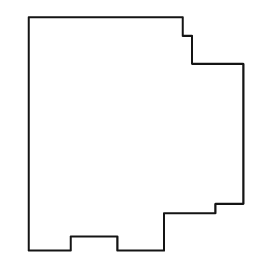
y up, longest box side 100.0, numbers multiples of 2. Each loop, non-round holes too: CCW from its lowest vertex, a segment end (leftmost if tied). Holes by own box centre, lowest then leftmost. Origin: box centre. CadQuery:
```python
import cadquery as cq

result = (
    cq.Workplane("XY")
    .moveTo(-46.0, -50.0)
    .lineTo(-28.0, -50.0)
    .lineTo(-28.0, -44.0)
    .lineTo(-8.0, -44.0)
    .lineTo(-8.0, -50.0)
    .lineTo(12.0, -50.0)
    .lineTo(12.0, -34.0)
    .lineTo(34.0, -34.0)
    .lineTo(34.0, -30.0)
    .lineTo(46.0, -30.0)
    .lineTo(46.0, 30.0)
    .lineTo(24.0, 30.0)
    .lineTo(24.0, 42.0)
    .lineTo(20.0, 42.0)
    .lineTo(20.0, 50.0)
    .lineTo(-46.0, 50.0)
    .close()
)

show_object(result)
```